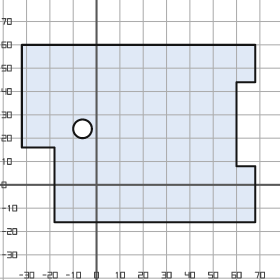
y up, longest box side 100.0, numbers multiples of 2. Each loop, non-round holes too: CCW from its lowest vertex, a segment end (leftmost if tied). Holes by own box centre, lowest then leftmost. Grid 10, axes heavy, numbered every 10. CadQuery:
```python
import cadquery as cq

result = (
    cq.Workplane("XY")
    .moveTo(-18.0, -16.0)
    .lineTo(68.0, -16.0)
    .lineTo(68.0, 8.0)
    .lineTo(60.0, 8.0)
    .lineTo(60.0, 44.0)
    .lineTo(68.0, 44.0)
    .lineTo(68.0, 60.0)
    .lineTo(-32.0, 60.0)
    .lineTo(-32.0, 16.0)
    .lineTo(-18.0, 16.0)
    .close()
    .moveTo(-6.0, 24.0)
    .circle(4.0)
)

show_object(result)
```